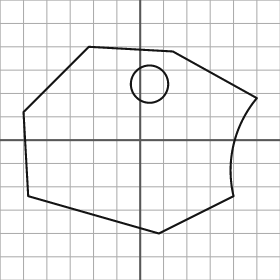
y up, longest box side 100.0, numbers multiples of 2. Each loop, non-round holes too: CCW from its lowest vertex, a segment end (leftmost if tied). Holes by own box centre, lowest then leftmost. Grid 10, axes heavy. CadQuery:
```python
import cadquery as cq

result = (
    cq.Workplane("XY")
    .moveTo(8.0, -40.0)
    .lineTo(40.0, -24.0)
    .threePointArc((40.0, -2.0), (50.0, 18.0))
    .lineTo(14.0, 38.0)
    .lineTo(-22.0, 40.0)
    .lineTo(-50.0, 12.0)
    .lineTo(-48.0, -24.0)
    .close()
    .moveTo(4.0, 24.0)
    .circle(8.0)
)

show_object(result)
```